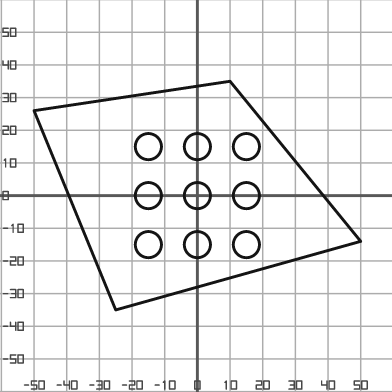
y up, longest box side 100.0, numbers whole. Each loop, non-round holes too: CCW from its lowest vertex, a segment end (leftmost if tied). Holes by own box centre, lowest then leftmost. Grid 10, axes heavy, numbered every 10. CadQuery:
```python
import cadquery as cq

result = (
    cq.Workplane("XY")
    .moveTo(-25.0, -35.0)
    .lineTo(50.0, -14.0)
    .lineTo(10.0, 35.0)
    .lineTo(-50.0, 26.0)
    .close()
    .moveTo(-15.0, -15.0)
    .circle(4.0)
    .moveTo(0.0, -15.0)
    .circle(4.0)
    .moveTo(15.0, -15.0)
    .circle(4.0)
    .moveTo(-15.0, 0.0)
    .circle(4.0)
    .moveTo(0.0, 0.0)
    .circle(4.0)
    .moveTo(15.0, 0.0)
    .circle(4.0)
    .moveTo(-15.0, 15.0)
    .circle(4.0)
    .moveTo(0.0, 15.0)
    .circle(4.0)
    .moveTo(15.0, 15.0)
    .circle(4.0)
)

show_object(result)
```